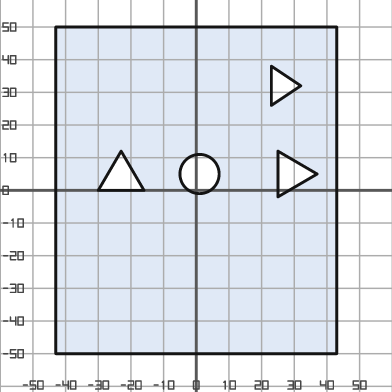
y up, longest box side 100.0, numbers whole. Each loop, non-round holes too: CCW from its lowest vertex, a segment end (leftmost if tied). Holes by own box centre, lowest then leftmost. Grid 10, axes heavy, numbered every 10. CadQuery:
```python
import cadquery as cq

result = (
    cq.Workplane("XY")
    .moveTo(-43.0, -50.0)
    .lineTo(43.0, -50.0)
    .lineTo(43.0, 50.0)
    .lineTo(-43.0, 50.0)
    .close()
    .moveTo(1.0, 5.0)
    .circle(6.0)
    .moveTo(25.0, -2.0)
    .lineTo(37.0, 5.0)
    .lineTo(25.0, 12.0)
    .close()
    .moveTo(-30.0, 0.0)
    .lineTo(-16.0, 0.0)
    .lineTo(-23.0, 12.0)
    .close()
    .moveTo(23.0, 26.0)
    .lineTo(32.0, 32.0)
    .lineTo(23.0, 38.0)
    .close()
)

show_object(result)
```